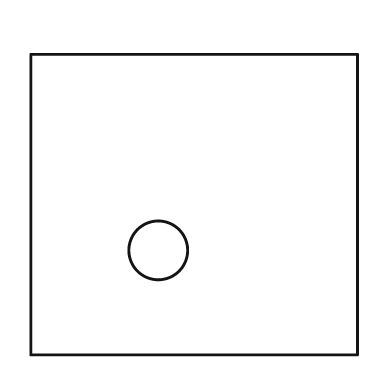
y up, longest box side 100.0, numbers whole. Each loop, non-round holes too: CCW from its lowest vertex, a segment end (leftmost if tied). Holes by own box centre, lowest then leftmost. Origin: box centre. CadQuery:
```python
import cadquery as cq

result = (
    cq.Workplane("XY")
    .moveTo(-50.0, -46.0)
    .lineTo(50.0, -46.0)
    .lineTo(50.0, 46.0)
    .lineTo(-50.0, 46.0)
    .close()
    .moveTo(-11.0, -14.0)
    .circle(9.0)
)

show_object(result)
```